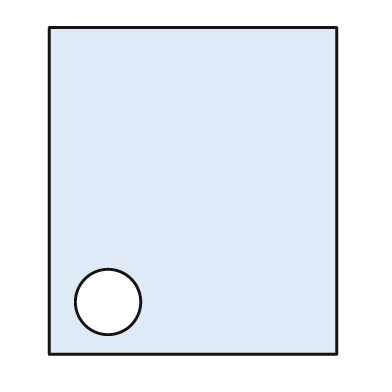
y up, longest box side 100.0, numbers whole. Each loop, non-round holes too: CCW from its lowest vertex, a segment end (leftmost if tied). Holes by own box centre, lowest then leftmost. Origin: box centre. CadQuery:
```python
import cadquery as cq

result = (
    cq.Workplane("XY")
    .moveTo(-44.0, -50.0)
    .lineTo(44.0, -50.0)
    .lineTo(44.0, 50.0)
    .lineTo(-44.0, 50.0)
    .close()
    .moveTo(-26.0, -34.0)
    .circle(10.0)
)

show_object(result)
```